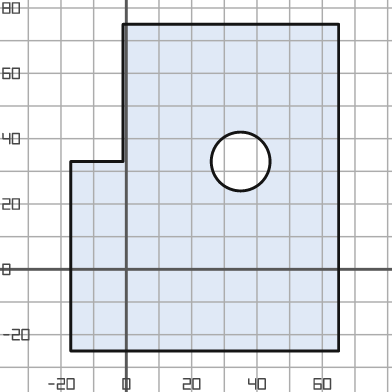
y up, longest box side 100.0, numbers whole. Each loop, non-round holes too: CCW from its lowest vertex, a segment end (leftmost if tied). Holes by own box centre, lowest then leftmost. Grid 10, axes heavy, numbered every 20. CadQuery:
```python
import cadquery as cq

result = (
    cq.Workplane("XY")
    .moveTo(-17.0, -25.0)
    .lineTo(65.0, -25.0)
    .lineTo(65.0, 75.0)
    .lineTo(-1.0, 75.0)
    .lineTo(-1.0, 33.0)
    .lineTo(-17.0, 33.0)
    .close()
    .moveTo(35.0, 33.0)
    .circle(9.0)
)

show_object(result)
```